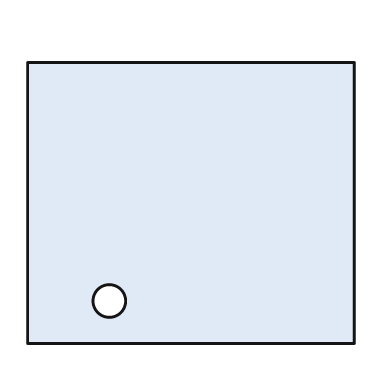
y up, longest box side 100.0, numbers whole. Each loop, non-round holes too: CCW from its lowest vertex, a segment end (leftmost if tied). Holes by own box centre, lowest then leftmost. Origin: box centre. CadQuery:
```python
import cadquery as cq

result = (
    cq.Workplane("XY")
    .moveTo(-50.0, -43.0)
    .lineTo(50.0, -43.0)
    .lineTo(50.0, 43.0)
    .lineTo(-50.0, 43.0)
    .close()
    .moveTo(-25.0, -30.0)
    .circle(5.0)
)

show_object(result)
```